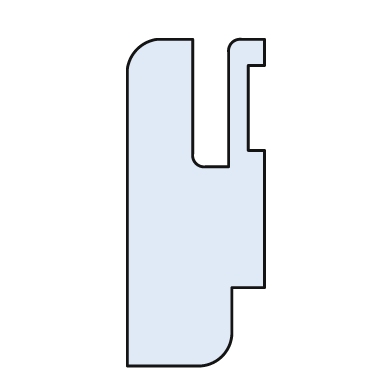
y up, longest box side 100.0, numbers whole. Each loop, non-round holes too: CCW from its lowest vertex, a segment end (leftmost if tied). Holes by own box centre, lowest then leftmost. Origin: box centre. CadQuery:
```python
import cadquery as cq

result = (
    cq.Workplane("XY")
    .moveTo(-21.0, -50.0)
    .lineTo(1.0, -50.0)
    .threePointArc((8.0, -47.0), (11.0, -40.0))
    .lineTo(11.0, -26.0)
    .lineTo(21.0, -26.0)
    .lineTo(21.0, 16.0)
    .lineTo(16.0, 16.0)
    .lineTo(16.0, 42.0)
    .lineTo(21.0, 42.0)
    .lineTo(21.0, 50.0)
    .lineTo(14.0, 50.0)
    .threePointArc((11.0, 49.0), (10.0, 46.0))
    .lineTo(10.0, 11.0)
    .lineTo(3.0, 11.0)
    .threePointArc((0.0, 12.0), (-1.0, 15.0))
    .lineTo(-1.0, 50.0)
    .lineTo(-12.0, 50.0)
    .threePointArc((-18.0, 47.0), (-21.0, 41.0))
    .close()
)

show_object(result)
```